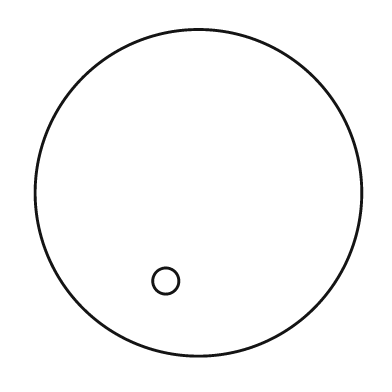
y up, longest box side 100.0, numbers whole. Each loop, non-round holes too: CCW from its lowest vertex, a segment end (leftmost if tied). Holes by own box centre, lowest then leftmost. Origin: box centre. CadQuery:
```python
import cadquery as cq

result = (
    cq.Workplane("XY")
    .moveTo(0.0, 0.0)
    .circle(50.0)
    .moveTo(-10.0, -27.0)
    .circle(4.0)
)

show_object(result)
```